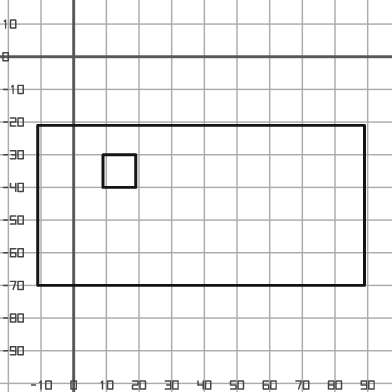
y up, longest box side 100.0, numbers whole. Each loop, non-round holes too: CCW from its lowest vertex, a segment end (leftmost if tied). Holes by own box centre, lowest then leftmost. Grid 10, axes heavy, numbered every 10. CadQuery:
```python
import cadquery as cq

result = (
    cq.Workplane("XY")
    .moveTo(-11.0, -70.0)
    .lineTo(89.0, -70.0)
    .lineTo(89.0, -21.0)
    .lineTo(-11.0, -21.0)
    .close()
    .moveTo(9.0, -40.0)
    .lineTo(19.0, -40.0)
    .lineTo(19.0, -30.0)
    .lineTo(9.0, -30.0)
    .close()
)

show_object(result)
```